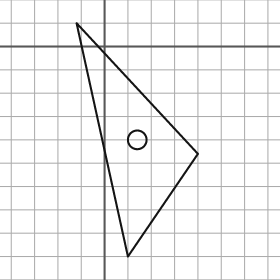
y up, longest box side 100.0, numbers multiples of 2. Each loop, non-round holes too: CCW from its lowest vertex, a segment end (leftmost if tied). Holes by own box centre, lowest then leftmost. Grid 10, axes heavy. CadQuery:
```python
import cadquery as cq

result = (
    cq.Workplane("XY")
    .moveTo(10.0, -90.0)
    .lineTo(40.0, -46.0)
    .lineTo(-12.0, 10.0)
    .close()
    .moveTo(14.0, -40.0)
    .circle(4.0)
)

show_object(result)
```